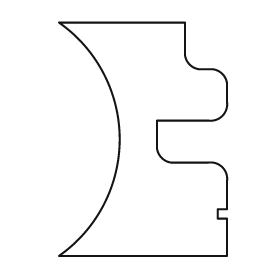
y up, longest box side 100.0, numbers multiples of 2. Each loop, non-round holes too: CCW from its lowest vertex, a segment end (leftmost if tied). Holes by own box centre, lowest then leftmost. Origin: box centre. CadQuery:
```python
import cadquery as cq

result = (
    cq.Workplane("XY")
    .moveTo(-36.0, -50.0)
    .lineTo(36.0, -50.0)
    .lineTo(36.0, -34.0)
    .lineTo(32.0, -34.0)
    .lineTo(32.0, -30.0)
    .lineTo(36.0, -30.0)
    .lineTo(36.0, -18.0)
    .threePointArc((34.0, -12.0), (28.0, -10.0))
    .lineTo(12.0, -10.0)
    .threePointArc((8.0, -8.0), (6.0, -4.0))
    .lineTo(6.0, 8.0)
    .lineTo(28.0, 8.0)
    .threePointArc((34.0, 10.0), (36.0, 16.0))
    .lineTo(36.0, 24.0)
    .threePointArc((34.0, 28.0), (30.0, 30.0))
    .lineTo(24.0, 30.0)
    .threePointArc((20.0, 32.0), (18.0, 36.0))
    .lineTo(18.0, 50.0)
    .lineTo(-36.0, 50.0)
    .threePointArc((-10.0, 0.0), (-36.0, -50.0))
    .close()
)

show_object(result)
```